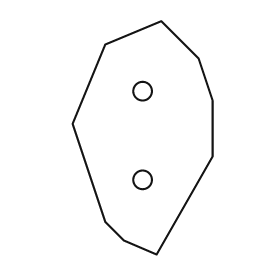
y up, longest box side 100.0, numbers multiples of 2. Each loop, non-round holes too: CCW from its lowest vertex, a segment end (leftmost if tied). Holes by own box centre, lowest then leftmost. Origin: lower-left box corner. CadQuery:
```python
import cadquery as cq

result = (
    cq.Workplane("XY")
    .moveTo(36.0, 0.0)
    .lineTo(60.0, 42.0)
    .lineTo(60.0, 66.0)
    .lineTo(54.0, 84.0)
    .lineTo(38.0, 100.0)
    .lineTo(14.0, 90.0)
    .lineTo(0.0, 56.0)
    .lineTo(14.0, 14.0)
    .lineTo(22.0, 6.0)
    .close()
    .moveTo(30.0, 32.0)
    .circle(4.0)
    .moveTo(30.0, 70.0)
    .circle(4.0)
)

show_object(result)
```